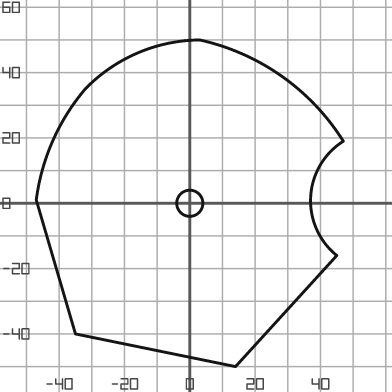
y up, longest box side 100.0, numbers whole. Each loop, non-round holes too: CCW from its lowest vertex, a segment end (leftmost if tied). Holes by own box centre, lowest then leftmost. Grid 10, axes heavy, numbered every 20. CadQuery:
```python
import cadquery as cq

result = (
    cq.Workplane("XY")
    .moveTo(14.0, -50.0)
    .lineTo(45.0, -16.0)
    .threePointArc((37.0, 2.0), (47.0, 19.0))
    .threePointArc((28.0, 39.0), (3.0, 50.0))
    .threePointArc((-16.0, 46.0), (-32.0, 35.0))
    .threePointArc((-42.0, 19.0), (-47.0, 1.0))
    .lineTo(-35.0, -40.0)
    .close()
    .moveTo(0.0, 0.0)
    .circle(4.0)
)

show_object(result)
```